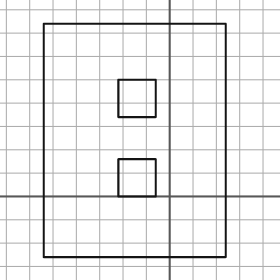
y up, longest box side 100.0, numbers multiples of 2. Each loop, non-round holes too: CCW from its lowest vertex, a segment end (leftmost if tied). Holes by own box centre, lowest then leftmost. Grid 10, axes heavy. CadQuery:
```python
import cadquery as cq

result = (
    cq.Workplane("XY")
    .moveTo(-54.0, -26.0)
    .lineTo(24.0, -26.0)
    .lineTo(24.0, 74.0)
    .lineTo(-54.0, 74.0)
    .close()
    .moveTo(-22.0, 0.0)
    .lineTo(-6.0, 0.0)
    .lineTo(-6.0, 16.0)
    .lineTo(-22.0, 16.0)
    .close()
    .moveTo(-22.0, 34.0)
    .lineTo(-6.0, 34.0)
    .lineTo(-6.0, 50.0)
    .lineTo(-22.0, 50.0)
    .close()
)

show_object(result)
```